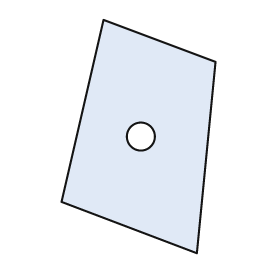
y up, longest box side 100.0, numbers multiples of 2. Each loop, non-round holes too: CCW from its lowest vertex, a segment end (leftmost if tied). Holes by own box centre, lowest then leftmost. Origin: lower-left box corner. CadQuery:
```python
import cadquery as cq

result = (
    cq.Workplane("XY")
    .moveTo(58.0, 0.0)
    .lineTo(66.0, 82.0)
    .lineTo(18.0, 100.0)
    .lineTo(0.0, 22.0)
    .close()
    .moveTo(34.0, 50.0)
    .circle(6.0)
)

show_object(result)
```